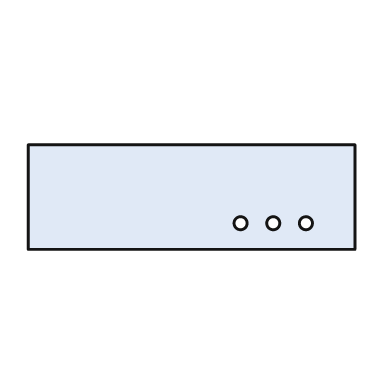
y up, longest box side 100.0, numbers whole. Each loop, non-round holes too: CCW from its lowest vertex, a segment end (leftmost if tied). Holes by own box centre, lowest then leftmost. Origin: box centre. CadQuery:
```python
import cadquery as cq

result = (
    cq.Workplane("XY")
    .moveTo(-50.0, -16.0)
    .lineTo(50.0, -16.0)
    .lineTo(50.0, 16.0)
    .lineTo(-50.0, 16.0)
    .close()
    .moveTo(15.0, -8.0)
    .circle(2.0)
    .moveTo(25.0, -8.0)
    .circle(2.0)
    .moveTo(35.0, -8.0)
    .circle(2.0)
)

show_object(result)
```